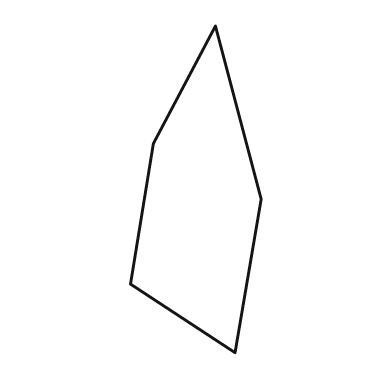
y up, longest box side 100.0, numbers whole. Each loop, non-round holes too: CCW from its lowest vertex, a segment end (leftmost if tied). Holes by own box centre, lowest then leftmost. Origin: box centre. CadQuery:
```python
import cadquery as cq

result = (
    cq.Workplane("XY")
    .moveTo(12.0, -50.0)
    .lineTo(20.0, -3.0)
    .lineTo(6.0, 50.0)
    .lineTo(-13.0, 14.0)
    .lineTo(-20.0, -29.0)
    .close()
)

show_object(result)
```